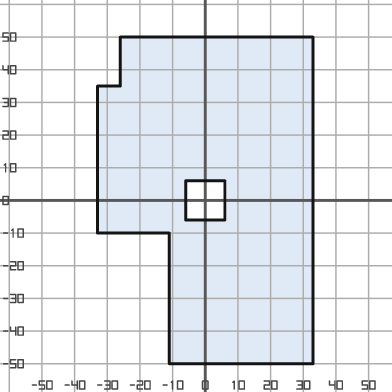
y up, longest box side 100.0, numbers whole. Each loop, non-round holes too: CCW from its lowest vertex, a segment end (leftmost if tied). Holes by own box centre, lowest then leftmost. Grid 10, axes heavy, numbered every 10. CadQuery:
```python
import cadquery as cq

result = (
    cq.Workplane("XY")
    .moveTo(-11.0, -50.0)
    .lineTo(33.0, -50.0)
    .lineTo(33.0, 50.0)
    .lineTo(-26.0, 50.0)
    .lineTo(-26.0, 35.0)
    .lineTo(-33.0, 35.0)
    .lineTo(-33.0, -10.0)
    .lineTo(-11.0, -10.0)
    .close()
    .moveTo(-6.0, -6.0)
    .lineTo(6.0, -6.0)
    .lineTo(6.0, 6.0)
    .lineTo(-6.0, 6.0)
    .close()
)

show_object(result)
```